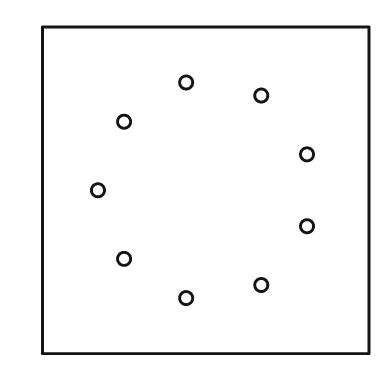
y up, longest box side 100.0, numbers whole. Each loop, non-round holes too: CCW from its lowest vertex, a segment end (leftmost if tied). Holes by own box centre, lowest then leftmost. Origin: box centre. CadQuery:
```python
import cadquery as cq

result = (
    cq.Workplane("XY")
    .moveTo(-50.0, -50.0)
    .lineTo(50.0, -50.0)
    .lineTo(50.0, 50.0)
    .lineTo(-50.0, 50.0)
    .close()
    .moveTo(-6.0, -33.0)
    .circle(2.0)
    .moveTo(17.0, -29.0)
    .circle(2.0)
    .moveTo(-25.0, -21.0)
    .circle(2.0)
    .moveTo(31.0, -11.0)
    .circle(2.0)
    .moveTo(-33.0, 0.0)
    .circle(2.0)
    .moveTo(31.0, 11.0)
    .circle(2.0)
    .moveTo(-25.0, 21.0)
    .circle(2.0)
    .moveTo(17.0, 29.0)
    .circle(2.0)
    .moveTo(-6.0, 33.0)
    .circle(2.0)
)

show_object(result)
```